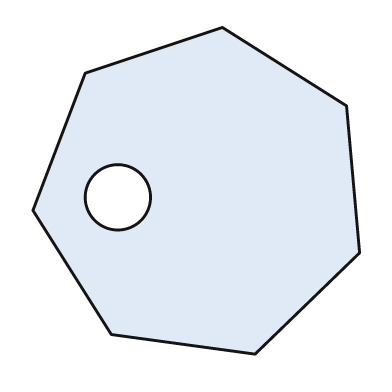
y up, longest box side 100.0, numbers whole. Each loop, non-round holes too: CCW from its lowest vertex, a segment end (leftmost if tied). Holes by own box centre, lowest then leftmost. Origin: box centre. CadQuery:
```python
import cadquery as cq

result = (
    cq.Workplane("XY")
    .moveTo(18.0, -50.0)
    .lineTo(50.0, -19.0)
    .lineTo(46.0, 26.0)
    .lineTo(8.0, 50.0)
    .lineTo(-34.0, 36.0)
    .lineTo(-50.0, -6.0)
    .lineTo(-26.0, -44.0)
    .close()
    .moveTo(-24.0, -2.0)
    .circle(10.0)
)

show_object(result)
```